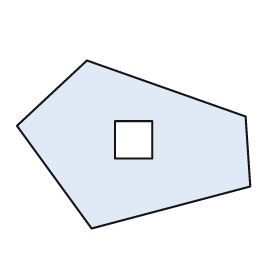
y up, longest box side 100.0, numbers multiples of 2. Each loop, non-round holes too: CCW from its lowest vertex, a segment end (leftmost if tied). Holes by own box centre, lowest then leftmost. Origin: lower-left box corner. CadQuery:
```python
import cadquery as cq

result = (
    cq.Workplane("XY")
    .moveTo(32.0, 0.0)
    .lineTo(100.0, 18.0)
    .lineTo(98.0, 48.0)
    .lineTo(30.0, 72.0)
    .lineTo(0.0, 44.0)
    .close()
    .moveTo(42.0, 30.0)
    .lineTo(58.0, 30.0)
    .lineTo(58.0, 46.0)
    .lineTo(42.0, 46.0)
    .close()
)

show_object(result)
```